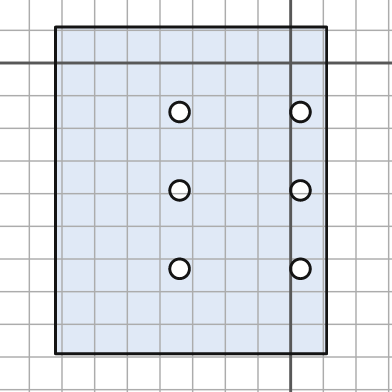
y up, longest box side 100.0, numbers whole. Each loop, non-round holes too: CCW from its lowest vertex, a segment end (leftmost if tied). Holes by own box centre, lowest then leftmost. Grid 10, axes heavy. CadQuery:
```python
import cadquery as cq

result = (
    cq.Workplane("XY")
    .moveTo(-72.0, -89.0)
    .lineTo(11.0, -89.0)
    .lineTo(11.0, 11.0)
    .lineTo(-72.0, 11.0)
    .close()
    .moveTo(-34.0, -63.0)
    .circle(3.0)
    .moveTo(3.0, -63.0)
    .circle(3.0)
    .moveTo(-34.0, -39.0)
    .circle(3.0)
    .moveTo(3.0, -39.0)
    .circle(3.0)
    .moveTo(-34.0, -15.0)
    .circle(3.0)
    .moveTo(3.0, -15.0)
    .circle(3.0)
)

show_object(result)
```